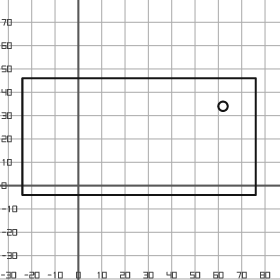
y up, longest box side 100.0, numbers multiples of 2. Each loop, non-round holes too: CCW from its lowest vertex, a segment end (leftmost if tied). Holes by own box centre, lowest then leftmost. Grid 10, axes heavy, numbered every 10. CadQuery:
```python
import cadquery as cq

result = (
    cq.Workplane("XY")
    .moveTo(-24.0, -4.0)
    .lineTo(76.0, -4.0)
    .lineTo(76.0, 46.0)
    .lineTo(-24.0, 46.0)
    .close()
    .moveTo(62.0, 34.0)
    .circle(2.0)
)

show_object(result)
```